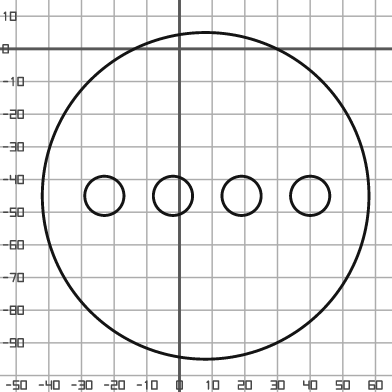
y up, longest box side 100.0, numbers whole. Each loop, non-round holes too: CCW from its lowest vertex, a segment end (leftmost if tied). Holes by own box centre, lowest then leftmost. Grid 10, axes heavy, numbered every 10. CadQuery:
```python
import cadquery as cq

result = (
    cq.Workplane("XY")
    .moveTo(8.0, -45.0)
    .circle(50.0)
    .moveTo(-23.0, -45.0)
    .circle(6.0)
    .moveTo(-2.0, -45.0)
    .circle(6.0)
    .moveTo(19.0, -45.0)
    .circle(6.0)
    .moveTo(40.0, -45.0)
    .circle(6.0)
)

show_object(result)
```